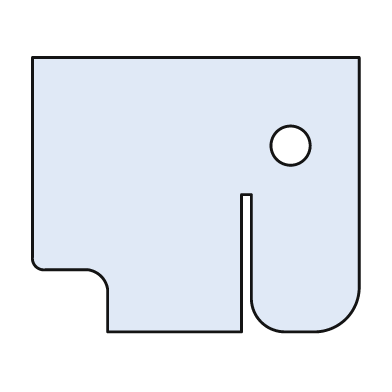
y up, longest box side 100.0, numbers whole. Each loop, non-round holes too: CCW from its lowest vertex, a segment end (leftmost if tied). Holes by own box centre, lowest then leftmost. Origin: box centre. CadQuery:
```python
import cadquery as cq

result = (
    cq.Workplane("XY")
    .moveTo(-27.0, -42.0)
    .lineTo(14.0, -42.0)
    .lineTo(14.0, 0.0)
    .lineTo(17.0, 0.0)
    .lineTo(17.0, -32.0)
    .threePointArc((20.0, -39.0), (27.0, -42.0))
    .lineTo(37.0, -42.0)
    .threePointArc((46.0, -38.0), (50.0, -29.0))
    .lineTo(50.0, 42.0)
    .lineTo(-50.0, 42.0)
    .lineTo(-50.0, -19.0)
    .threePointArc((-49.0, -22.0), (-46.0, -23.0))
    .lineTo(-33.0, -23.0)
    .threePointArc((-29.0, -25.0), (-27.0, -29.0))
    .close()
    .moveTo(29.0, 15.0)
    .circle(6.0)
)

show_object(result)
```